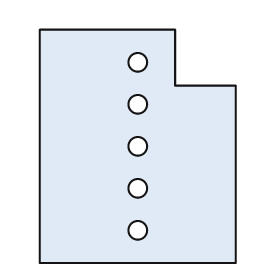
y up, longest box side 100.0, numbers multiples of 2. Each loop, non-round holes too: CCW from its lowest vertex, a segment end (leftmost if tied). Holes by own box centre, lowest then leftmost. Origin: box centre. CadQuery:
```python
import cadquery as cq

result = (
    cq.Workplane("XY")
    .moveTo(-42.0, -50.0)
    .lineTo(42.0, -50.0)
    .lineTo(42.0, 26.0)
    .lineTo(16.0, 26.0)
    .lineTo(16.0, 50.0)
    .lineTo(-42.0, 50.0)
    .close()
    .moveTo(0.0, -36.0)
    .circle(4.0)
    .moveTo(0.0, -18.0)
    .circle(4.0)
    .moveTo(0.0, 0.0)
    .circle(4.0)
    .moveTo(0.0, 18.0)
    .circle(4.0)
    .moveTo(0.0, 36.0)
    .circle(4.0)
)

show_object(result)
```